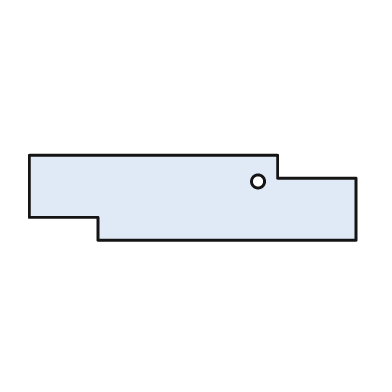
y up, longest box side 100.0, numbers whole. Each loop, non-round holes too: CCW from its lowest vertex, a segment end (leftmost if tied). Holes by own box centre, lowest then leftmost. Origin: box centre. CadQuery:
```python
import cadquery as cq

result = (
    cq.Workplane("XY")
    .moveTo(-29.0, -13.0)
    .lineTo(50.0, -13.0)
    .lineTo(50.0, 6.0)
    .lineTo(26.0, 6.0)
    .lineTo(26.0, 13.0)
    .lineTo(-50.0, 13.0)
    .lineTo(-50.0, -6.0)
    .lineTo(-29.0, -6.0)
    .close()
    .moveTo(20.0, 5.0)
    .circle(2.0)
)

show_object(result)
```